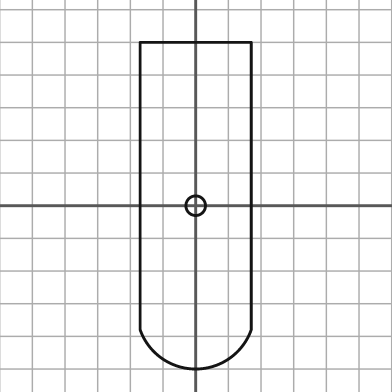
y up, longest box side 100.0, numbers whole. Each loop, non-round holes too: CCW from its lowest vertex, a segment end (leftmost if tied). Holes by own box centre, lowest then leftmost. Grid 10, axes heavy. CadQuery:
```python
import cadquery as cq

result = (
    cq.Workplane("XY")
    .moveTo(-17.0, -38.0)
    .threePointArc((0.0, -50.0), (17.0, -38.0))
    .lineTo(17.0, 50.0)
    .lineTo(-17.0, 50.0)
    .close()
    .moveTo(0.0, 0.0)
    .circle(3.0)
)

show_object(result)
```